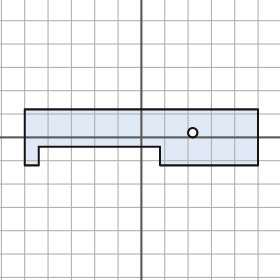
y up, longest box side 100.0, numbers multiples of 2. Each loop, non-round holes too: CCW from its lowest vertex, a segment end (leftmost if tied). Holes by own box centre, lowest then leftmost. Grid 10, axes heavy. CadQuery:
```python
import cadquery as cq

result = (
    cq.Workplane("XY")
    .moveTo(-50.0, -12.0)
    .lineTo(-44.0, -12.0)
    .lineTo(-44.0, -4.0)
    .lineTo(8.0, -4.0)
    .lineTo(8.0, -12.0)
    .lineTo(50.0, -12.0)
    .lineTo(50.0, 12.0)
    .lineTo(-50.0, 12.0)
    .close()
    .moveTo(22.0, 2.0)
    .circle(2.0)
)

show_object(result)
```